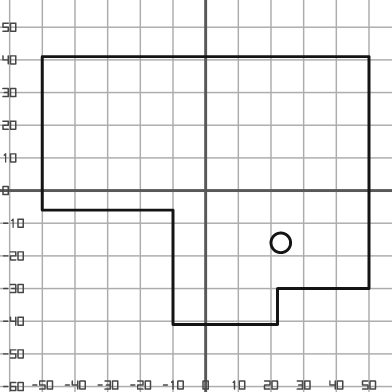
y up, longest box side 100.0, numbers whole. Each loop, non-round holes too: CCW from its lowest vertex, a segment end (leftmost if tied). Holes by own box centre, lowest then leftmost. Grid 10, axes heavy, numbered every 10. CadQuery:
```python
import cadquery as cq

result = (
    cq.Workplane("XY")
    .moveTo(-10.0, -41.0)
    .lineTo(22.0, -41.0)
    .lineTo(22.0, -30.0)
    .lineTo(50.0, -30.0)
    .lineTo(50.0, 41.0)
    .lineTo(-50.0, 41.0)
    .lineTo(-50.0, -6.0)
    .lineTo(-10.0, -6.0)
    .close()
    .moveTo(23.0, -16.0)
    .circle(3.0)
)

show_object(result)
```